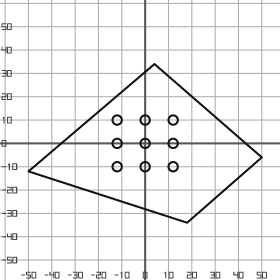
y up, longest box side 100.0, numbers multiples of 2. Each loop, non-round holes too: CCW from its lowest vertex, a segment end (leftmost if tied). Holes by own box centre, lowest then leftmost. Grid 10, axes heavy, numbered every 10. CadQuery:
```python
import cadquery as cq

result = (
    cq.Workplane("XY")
    .moveTo(18.0, -34.0)
    .lineTo(50.0, -6.0)
    .lineTo(4.0, 34.0)
    .lineTo(-50.0, -12.0)
    .close()
    .moveTo(-12.0, -10.0)
    .circle(2.0)
    .moveTo(0.0, -10.0)
    .circle(2.0)
    .moveTo(12.0, -10.0)
    .circle(2.0)
    .moveTo(-12.0, 0.0)
    .circle(2.0)
    .moveTo(0.0, 0.0)
    .circle(2.0)
    .moveTo(12.0, 0.0)
    .circle(2.0)
    .moveTo(-12.0, 10.0)
    .circle(2.0)
    .moveTo(0.0, 10.0)
    .circle(2.0)
    .moveTo(12.0, 10.0)
    .circle(2.0)
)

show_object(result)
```